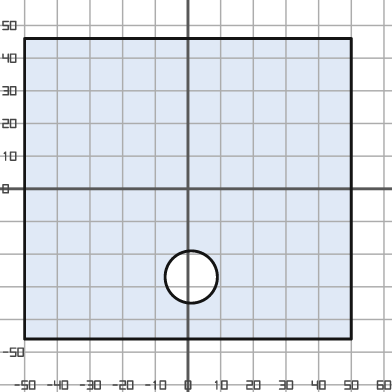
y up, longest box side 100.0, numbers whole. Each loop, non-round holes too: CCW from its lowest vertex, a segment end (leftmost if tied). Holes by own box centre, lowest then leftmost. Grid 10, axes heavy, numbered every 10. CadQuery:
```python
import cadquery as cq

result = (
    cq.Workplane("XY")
    .moveTo(-50.0, -46.0)
    .lineTo(50.0, -46.0)
    .lineTo(50.0, 46.0)
    .lineTo(-50.0, 46.0)
    .close()
    .moveTo(1.0, -27.0)
    .circle(8.0)
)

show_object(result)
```